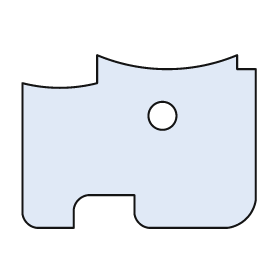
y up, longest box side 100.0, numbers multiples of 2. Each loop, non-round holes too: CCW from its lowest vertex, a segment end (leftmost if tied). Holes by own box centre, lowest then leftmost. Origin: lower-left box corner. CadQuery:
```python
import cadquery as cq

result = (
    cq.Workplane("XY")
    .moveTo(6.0, 0.0)
    .lineTo(22.0, 0.0)
    .lineTo(22.0, 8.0)
    .threePointArc((24.0, 12.0), (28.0, 14.0))
    .lineTo(48.0, 14.0)
    .lineTo(48.0, 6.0)
    .threePointArc((50.0, 2.0), (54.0, 0.0))
    .lineTo(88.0, 0.0)
    .threePointArc((96.0, 4.0), (100.0, 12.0))
    .lineTo(100.0, 68.0)
    .lineTo(92.0, 68.0)
    .lineTo(92.0, 74.0)
    .threePointArc((62.0, 68.0), (32.0, 74.0))
    .lineTo(32.0, 62.0)
    .threePointArc((16.0, 60.0), (0.0, 62.0))
    .lineTo(0.0, 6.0)
    .threePointArc((2.0, 2.0), (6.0, 0.0))
    .close()
    .moveTo(60.0, 48.0)
    .circle(6.0)
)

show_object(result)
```